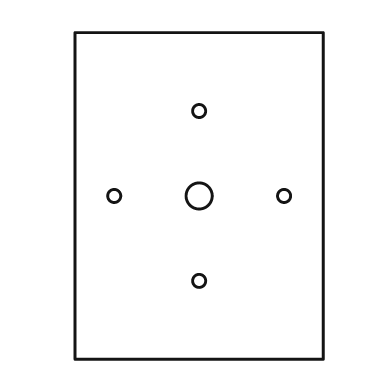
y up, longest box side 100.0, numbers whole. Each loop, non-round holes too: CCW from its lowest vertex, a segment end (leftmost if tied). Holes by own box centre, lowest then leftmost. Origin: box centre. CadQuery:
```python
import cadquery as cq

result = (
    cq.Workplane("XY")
    .moveTo(-38.0, -50.0)
    .lineTo(38.0, -50.0)
    .lineTo(38.0, 50.0)
    .lineTo(-38.0, 50.0)
    .close()
    .moveTo(0.0, -26.0)
    .circle(2.0)
    .moveTo(-26.0, 0.0)
    .circle(2.0)
    .moveTo(0.0, 0.0)
    .circle(4.0)
    .moveTo(26.0, 0.0)
    .circle(2.0)
    .moveTo(0.0, 26.0)
    .circle(2.0)
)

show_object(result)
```